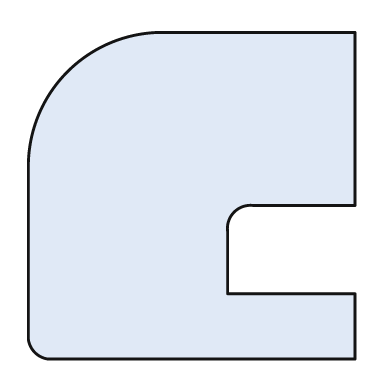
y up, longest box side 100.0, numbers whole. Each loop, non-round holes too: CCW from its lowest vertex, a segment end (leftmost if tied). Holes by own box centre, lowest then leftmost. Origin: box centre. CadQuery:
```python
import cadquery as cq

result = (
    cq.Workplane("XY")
    .moveTo(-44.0, -50.0)
    .lineTo(50.0, -50.0)
    .lineTo(50.0, -30.0)
    .lineTo(11.0, -30.0)
    .lineTo(11.0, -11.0)
    .threePointArc((13.0, -5.0), (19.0, -3.0))
    .lineTo(50.0, -3.0)
    .lineTo(50.0, 50.0)
    .lineTo(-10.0, 50.0)
    .threePointArc((-38.0, 38.0), (-50.0, 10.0))
    .lineTo(-50.0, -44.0)
    .threePointArc((-48.0, -48.0), (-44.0, -50.0))
    .close()
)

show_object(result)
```